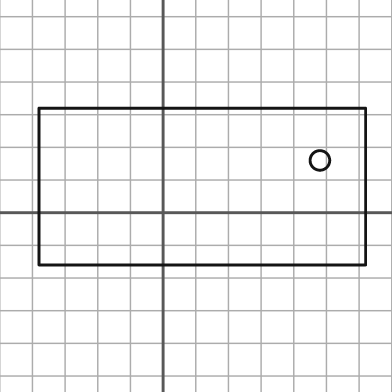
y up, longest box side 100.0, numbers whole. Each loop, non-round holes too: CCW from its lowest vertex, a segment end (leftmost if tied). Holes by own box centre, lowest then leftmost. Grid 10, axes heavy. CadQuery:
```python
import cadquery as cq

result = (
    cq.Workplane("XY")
    .moveTo(-38.0, -16.0)
    .lineTo(62.0, -16.0)
    .lineTo(62.0, 32.0)
    .lineTo(-38.0, 32.0)
    .close()
    .moveTo(48.0, 16.0)
    .circle(3.0)
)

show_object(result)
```